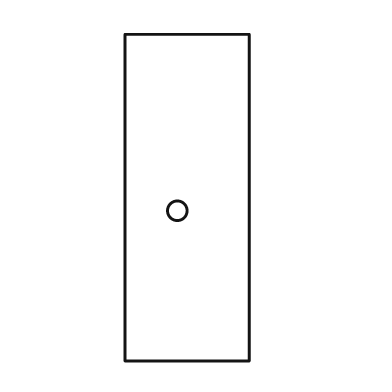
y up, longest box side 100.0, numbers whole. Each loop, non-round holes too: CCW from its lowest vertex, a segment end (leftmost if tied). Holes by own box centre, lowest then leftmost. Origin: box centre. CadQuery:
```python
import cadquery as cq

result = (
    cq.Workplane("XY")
    .moveTo(-19.0, -50.0)
    .lineTo(19.0, -50.0)
    .lineTo(19.0, 50.0)
    .lineTo(-19.0, 50.0)
    .close()
    .moveTo(-3.0, -4.0)
    .circle(3.0)
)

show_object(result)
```